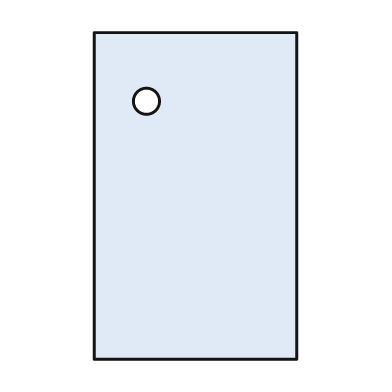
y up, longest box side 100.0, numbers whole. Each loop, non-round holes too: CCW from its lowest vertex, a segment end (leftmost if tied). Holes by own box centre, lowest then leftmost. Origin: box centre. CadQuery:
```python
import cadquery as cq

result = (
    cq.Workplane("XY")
    .moveTo(-31.0, -50.0)
    .lineTo(31.0, -50.0)
    .lineTo(31.0, 50.0)
    .lineTo(-31.0, 50.0)
    .close()
    .moveTo(-15.0, 29.0)
    .circle(4.0)
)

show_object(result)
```